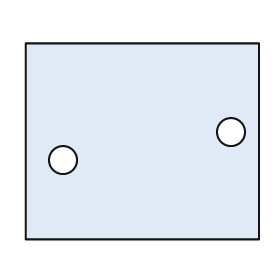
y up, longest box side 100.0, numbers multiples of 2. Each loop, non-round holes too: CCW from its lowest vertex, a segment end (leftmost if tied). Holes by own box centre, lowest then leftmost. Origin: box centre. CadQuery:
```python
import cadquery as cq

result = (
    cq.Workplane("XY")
    .moveTo(-50.0, -42.0)
    .lineTo(50.0, -42.0)
    .lineTo(50.0, 42.0)
    .lineTo(-50.0, 42.0)
    .close()
    .moveTo(-34.0, -8.0)
    .circle(6.0)
    .moveTo(38.0, 4.0)
    .circle(6.0)
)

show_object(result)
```